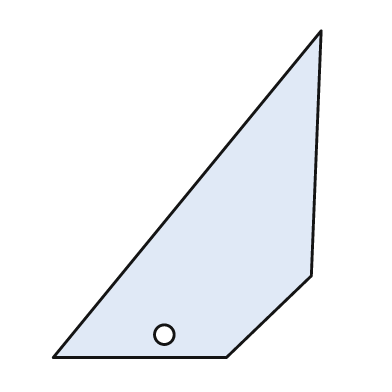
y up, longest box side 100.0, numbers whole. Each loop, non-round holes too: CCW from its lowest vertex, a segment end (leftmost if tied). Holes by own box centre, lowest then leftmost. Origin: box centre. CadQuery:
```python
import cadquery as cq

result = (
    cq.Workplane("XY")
    .moveTo(-41.0, -50.0)
    .lineTo(12.0, -50.0)
    .lineTo(38.0, -25.0)
    .lineTo(41.0, 50.0)
    .close()
    .moveTo(-7.0, -43.0)
    .circle(3.0)
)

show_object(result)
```